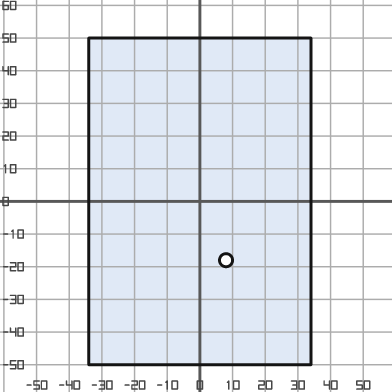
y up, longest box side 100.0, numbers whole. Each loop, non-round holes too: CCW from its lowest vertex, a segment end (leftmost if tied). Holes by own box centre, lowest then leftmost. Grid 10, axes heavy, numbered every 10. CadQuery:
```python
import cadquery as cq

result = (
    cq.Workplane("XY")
    .moveTo(-34.0, -50.0)
    .lineTo(34.0, -50.0)
    .lineTo(34.0, 50.0)
    .lineTo(-34.0, 50.0)
    .close()
    .moveTo(8.0, -18.0)
    .circle(2.0)
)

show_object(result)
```